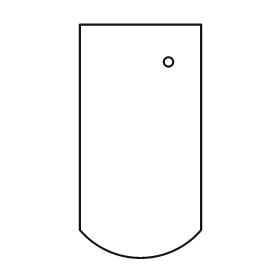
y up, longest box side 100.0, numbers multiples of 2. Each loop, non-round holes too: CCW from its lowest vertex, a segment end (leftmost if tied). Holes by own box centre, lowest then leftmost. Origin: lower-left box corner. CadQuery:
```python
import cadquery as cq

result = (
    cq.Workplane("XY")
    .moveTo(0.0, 12.0)
    .threePointArc((26.0, 0.0), (52.0, 12.0))
    .lineTo(52.0, 100.0)
    .lineTo(0.0, 100.0)
    .close()
    .moveTo(38.0, 84.0)
    .circle(2.0)
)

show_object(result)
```